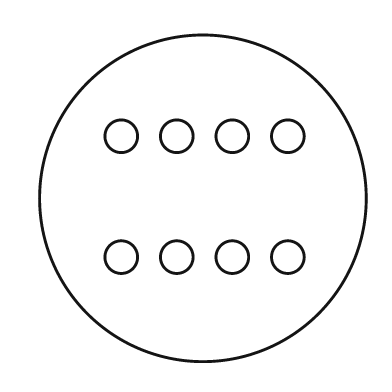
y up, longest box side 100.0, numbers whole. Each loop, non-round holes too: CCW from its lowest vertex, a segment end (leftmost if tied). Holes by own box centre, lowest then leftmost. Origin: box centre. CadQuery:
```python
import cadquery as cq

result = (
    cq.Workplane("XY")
    .moveTo(0.0, 0.0)
    .circle(50.0)
    .moveTo(-25.0, -18.0)
    .circle(5.0)
    .moveTo(-8.0, -18.0)
    .circle(5.0)
    .moveTo(9.0, -18.0)
    .circle(5.0)
    .moveTo(26.0, -18.0)
    .circle(5.0)
    .moveTo(-25.0, 19.0)
    .circle(5.0)
    .moveTo(-8.0, 19.0)
    .circle(5.0)
    .moveTo(9.0, 19.0)
    .circle(5.0)
    .moveTo(26.0, 19.0)
    .circle(5.0)
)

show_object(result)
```